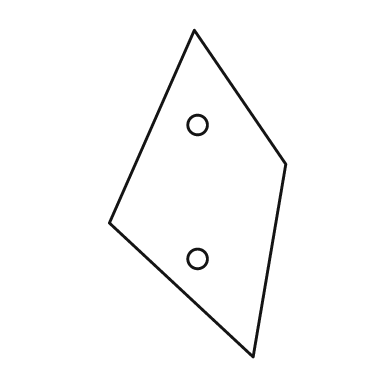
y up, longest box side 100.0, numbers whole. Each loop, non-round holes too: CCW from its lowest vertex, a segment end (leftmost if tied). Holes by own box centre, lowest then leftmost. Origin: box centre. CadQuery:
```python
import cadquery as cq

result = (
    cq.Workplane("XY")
    .moveTo(17.0, -50.0)
    .lineTo(27.0, 9.0)
    .lineTo(-1.0, 50.0)
    .lineTo(-27.0, -9.0)
    .close()
    .moveTo(0.0, -20.0)
    .circle(3.0)
    .moveTo(0.0, 21.0)
    .circle(3.0)
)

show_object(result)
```